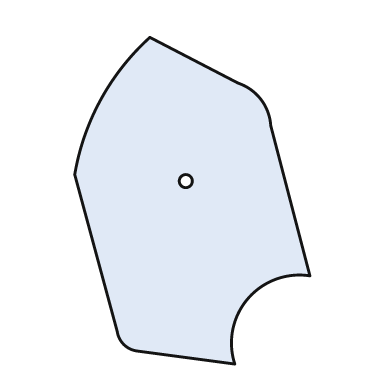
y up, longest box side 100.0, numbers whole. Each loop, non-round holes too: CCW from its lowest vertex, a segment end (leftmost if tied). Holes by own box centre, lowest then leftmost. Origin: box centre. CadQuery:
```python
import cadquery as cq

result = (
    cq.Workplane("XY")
    .moveTo(13.0, -50.0)
    .threePointArc((17.0, -30.0), (36.0, -23.0))
    .lineTo(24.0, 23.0)
    .threePointArc((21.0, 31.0), (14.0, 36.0))
    .lineTo(-13.0, 50.0)
    .threePointArc((-28.0, 31.0), (-36.0, 8.0))
    .lineTo(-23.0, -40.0)
    .threePointArc((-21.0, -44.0), (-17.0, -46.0))
    .close()
    .moveTo(-2.0, 6.0)
    .circle(2.0)
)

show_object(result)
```